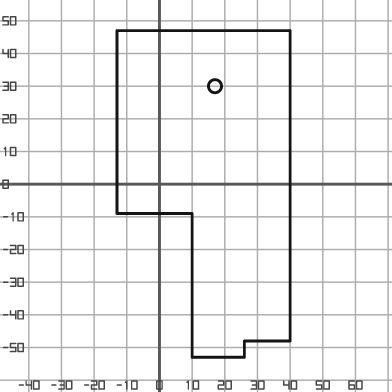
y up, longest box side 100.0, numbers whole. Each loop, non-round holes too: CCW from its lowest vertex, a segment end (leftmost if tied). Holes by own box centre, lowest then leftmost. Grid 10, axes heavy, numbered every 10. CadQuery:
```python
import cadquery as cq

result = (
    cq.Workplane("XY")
    .moveTo(10.0, -53.0)
    .lineTo(26.0, -53.0)
    .lineTo(26.0, -48.0)
    .lineTo(40.0, -48.0)
    .lineTo(40.0, 47.0)
    .lineTo(-13.0, 47.0)
    .lineTo(-13.0, -9.0)
    .lineTo(10.0, -9.0)
    .close()
    .moveTo(17.0, 30.0)
    .circle(2.0)
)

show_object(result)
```